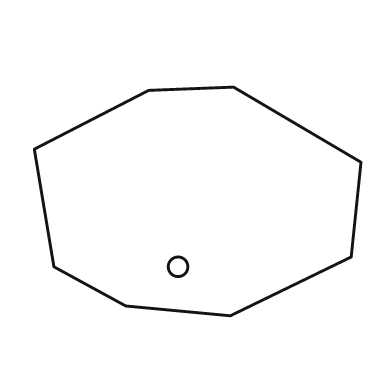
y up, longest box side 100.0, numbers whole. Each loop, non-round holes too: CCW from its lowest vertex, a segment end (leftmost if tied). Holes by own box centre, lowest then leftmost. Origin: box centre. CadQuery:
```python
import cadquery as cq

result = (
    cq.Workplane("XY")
    .moveTo(10.0, -35.0)
    .lineTo(47.0, -17.0)
    .lineTo(50.0, 12.0)
    .lineTo(11.0, 35.0)
    .lineTo(-15.0, 34.0)
    .lineTo(-50.0, 16.0)
    .lineTo(-44.0, -20.0)
    .lineTo(-22.0, -32.0)
    .close()
    .moveTo(-6.0, -20.0)
    .circle(3.0)
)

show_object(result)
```